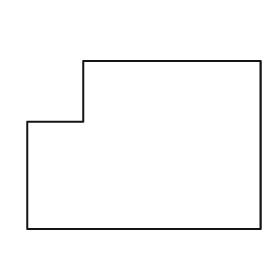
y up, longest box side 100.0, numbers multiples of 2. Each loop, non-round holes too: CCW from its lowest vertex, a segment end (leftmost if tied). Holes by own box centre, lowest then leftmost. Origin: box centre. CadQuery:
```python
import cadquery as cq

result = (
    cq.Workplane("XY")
    .moveTo(-50.0, -36.0)
    .lineTo(50.0, -36.0)
    .lineTo(50.0, 36.0)
    .lineTo(-26.0, 36.0)
    .lineTo(-26.0, 10.0)
    .lineTo(-50.0, 10.0)
    .close()
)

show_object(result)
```